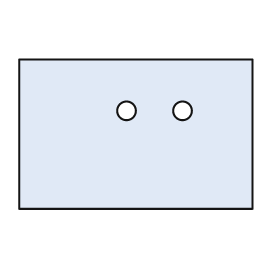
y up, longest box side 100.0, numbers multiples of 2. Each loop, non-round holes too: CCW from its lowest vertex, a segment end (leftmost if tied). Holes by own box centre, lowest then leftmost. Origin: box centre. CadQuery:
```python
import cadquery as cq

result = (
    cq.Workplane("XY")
    .moveTo(-50.0, -32.0)
    .lineTo(50.0, -32.0)
    .lineTo(50.0, 32.0)
    .lineTo(-50.0, 32.0)
    .close()
    .moveTo(-4.0, 10.0)
    .circle(4.0)
    .moveTo(20.0, 10.0)
    .circle(4.0)
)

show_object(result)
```